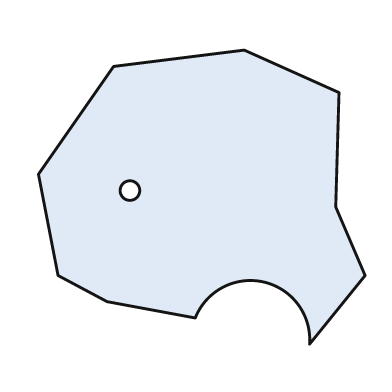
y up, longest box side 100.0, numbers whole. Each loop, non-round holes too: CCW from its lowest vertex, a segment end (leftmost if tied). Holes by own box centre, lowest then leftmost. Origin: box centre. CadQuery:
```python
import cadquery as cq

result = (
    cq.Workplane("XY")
    .moveTo(33.0, -45.0)
    .lineTo(50.0, -24.0)
    .lineTo(41.0, -3.0)
    .lineTo(42.0, 32.0)
    .lineTo(13.0, 45.0)
    .lineTo(-27.0, 40.0)
    .lineTo(-50.0, 7.0)
    .lineTo(-44.0, -24.0)
    .lineTo(-29.0, -32.0)
    .lineTo(-2.0, -37.0)
    .threePointArc((19.0, -26.0), (33.0, -45.0))
    .close()
    .moveTo(-22.0, 2.0)
    .circle(3.0)
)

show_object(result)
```